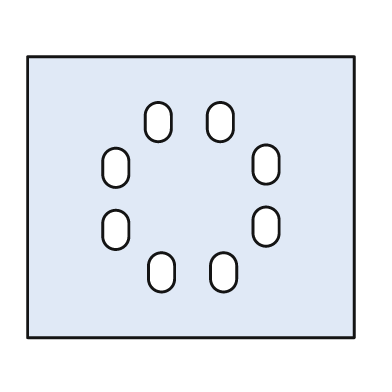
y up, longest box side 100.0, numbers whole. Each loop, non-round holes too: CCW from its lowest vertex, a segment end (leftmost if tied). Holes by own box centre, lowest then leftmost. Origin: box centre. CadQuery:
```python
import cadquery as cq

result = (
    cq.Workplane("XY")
    .moveTo(-50.0, -43.0)
    .lineTo(50.0, -43.0)
    .lineTo(50.0, 43.0)
    .lineTo(-50.0, 43.0)
    .close()
    .moveTo(-13.0, -25.0)
    .threePointArc((-9.0, -29.0), (-5.0, -25.0))
    .lineTo(-5.0, -21.0)
    .threePointArc((-9.0, -17.0), (-13.0, -21.0))
    .close()
    .moveTo(6.0, -25.0)
    .threePointArc((10.0, -29.0), (14.0, -25.0))
    .lineTo(14.0, -21.0)
    .threePointArc((10.0, -17.0), (6.0, -21.0))
    .close()
    .moveTo(-27.0, -12.0)
    .threePointArc((-23.0, -16.0), (-19.0, -12.0))
    .lineTo(-19.0, -8.0)
    .threePointArc((-23.0, -4.0), (-27.0, -8.0))
    .close()
    .moveTo(19.0, -11.0)
    .threePointArc((23.0, -15.0), (27.0, -11.0))
    .lineTo(27.0, -7.0)
    .threePointArc((23.0, -3.0), (19.0, -7.0))
    .close()
    .moveTo(-27.0, 7.0)
    .threePointArc((-23.0, 3.0), (-19.0, 7.0))
    .lineTo(-19.0, 11.0)
    .threePointArc((-23.0, 15.0), (-27.0, 11.0))
    .close()
    .moveTo(19.0, 8.0)
    .threePointArc((23.0, 4.0), (27.0, 8.0))
    .lineTo(27.0, 12.0)
    .threePointArc((23.0, 16.0), (19.0, 12.0))
    .close()
    .moveTo(-14.0, 21.0)
    .threePointArc((-10.0, 17.0), (-6.0, 21.0))
    .lineTo(-6.0, 25.0)
    .threePointArc((-10.0, 29.0), (-14.0, 25.0))
    .close()
    .moveTo(5.0, 21.0)
    .threePointArc((9.0, 17.0), (13.0, 21.0))
    .lineTo(13.0, 25.0)
    .threePointArc((9.0, 29.0), (5.0, 25.0))
    .close()
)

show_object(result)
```